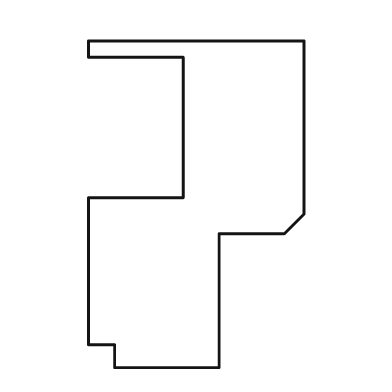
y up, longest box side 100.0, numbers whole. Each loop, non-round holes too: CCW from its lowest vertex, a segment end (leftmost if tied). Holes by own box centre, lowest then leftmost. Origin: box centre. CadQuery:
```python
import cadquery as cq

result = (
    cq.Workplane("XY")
    .moveTo(-25.0, -50.0)
    .lineTo(7.0, -50.0)
    .lineTo(7.0, -9.0)
    .lineTo(27.0, -9.0)
    .lineTo(33.0, -3.0)
    .lineTo(33.0, 50.0)
    .lineTo(-33.0, 50.0)
    .lineTo(-33.0, 45.0)
    .lineTo(-4.0, 45.0)
    .lineTo(-4.0, 2.0)
    .lineTo(-33.0, 2.0)
    .lineTo(-33.0, -43.0)
    .lineTo(-25.0, -43.0)
    .close()
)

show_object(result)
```